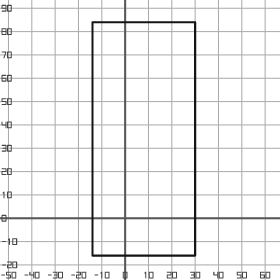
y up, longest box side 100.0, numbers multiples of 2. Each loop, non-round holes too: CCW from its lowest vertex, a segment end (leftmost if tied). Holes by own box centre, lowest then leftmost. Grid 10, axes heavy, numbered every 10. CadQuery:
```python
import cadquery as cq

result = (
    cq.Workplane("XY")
    .moveTo(-14.0, -16.0)
    .lineTo(30.0, -16.0)
    .lineTo(30.0, 84.0)
    .lineTo(-14.0, 84.0)
    .close()
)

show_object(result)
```